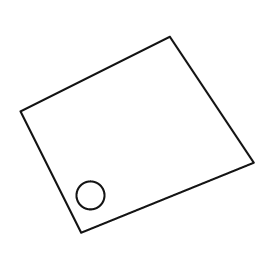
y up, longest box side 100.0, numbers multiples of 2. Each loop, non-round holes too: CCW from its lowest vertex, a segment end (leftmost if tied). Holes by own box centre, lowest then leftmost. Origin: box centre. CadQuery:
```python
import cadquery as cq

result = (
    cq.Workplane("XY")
    .moveTo(-24.0, -42.0)
    .lineTo(50.0, -12.0)
    .lineTo(14.0, 42.0)
    .lineTo(-50.0, 10.0)
    .close()
    .moveTo(-20.0, -26.0)
    .circle(6.0)
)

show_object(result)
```